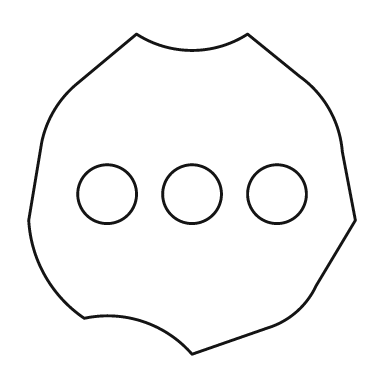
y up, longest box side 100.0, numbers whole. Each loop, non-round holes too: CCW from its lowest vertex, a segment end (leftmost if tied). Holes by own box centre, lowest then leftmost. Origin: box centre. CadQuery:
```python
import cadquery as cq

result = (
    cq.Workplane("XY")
    .moveTo(0.0, -49.0)
    .lineTo(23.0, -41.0)
    .threePointArc((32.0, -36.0), (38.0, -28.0))
    .lineTo(50.0, -8.0)
    .lineTo(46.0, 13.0)
    .threePointArc((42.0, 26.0), (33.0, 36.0))
    .lineTo(17.0, 49.0)
    .threePointArc((0.0, 44.0), (-17.0, 49.0))
    .lineTo(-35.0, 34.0)
    .threePointArc((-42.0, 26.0), (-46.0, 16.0))
    .lineTo(-50.0, -8.0)
    .threePointArc((-45.0, -25.0), (-33.0, -38.0))
    .threePointArc((-15.0, -39.0), (0.0, -49.0))
    .close()
    .moveTo(-26.0, 0.0)
    .circle(9.0)
    .moveTo(0.0, 0.0)
    .circle(9.0)
    .moveTo(26.0, 0.0)
    .circle(9.0)
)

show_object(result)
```